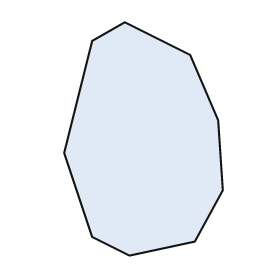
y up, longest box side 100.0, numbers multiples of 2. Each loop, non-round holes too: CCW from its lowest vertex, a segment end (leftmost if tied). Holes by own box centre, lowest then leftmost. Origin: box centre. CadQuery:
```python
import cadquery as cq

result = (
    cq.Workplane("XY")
    .moveTo(-6.0, -50.0)
    .lineTo(22.0, -44.0)
    .lineTo(34.0, -22.0)
    .lineTo(32.0, 8.0)
    .lineTo(20.0, 36.0)
    .lineTo(-8.0, 50.0)
    .lineTo(-22.0, 42.0)
    .lineTo(-34.0, -6.0)
    .lineTo(-22.0, -42.0)
    .close()
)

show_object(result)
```